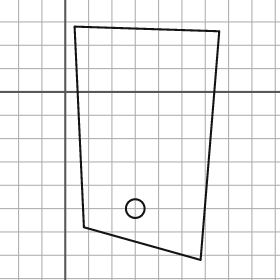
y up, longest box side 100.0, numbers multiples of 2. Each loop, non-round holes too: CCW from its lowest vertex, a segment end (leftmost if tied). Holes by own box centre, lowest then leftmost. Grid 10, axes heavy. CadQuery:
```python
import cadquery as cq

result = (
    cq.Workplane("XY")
    .moveTo(58.0, -72.0)
    .lineTo(66.0, 26.0)
    .lineTo(4.0, 28.0)
    .lineTo(8.0, -58.0)
    .close()
    .moveTo(30.0, -50.0)
    .circle(4.0)
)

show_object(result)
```